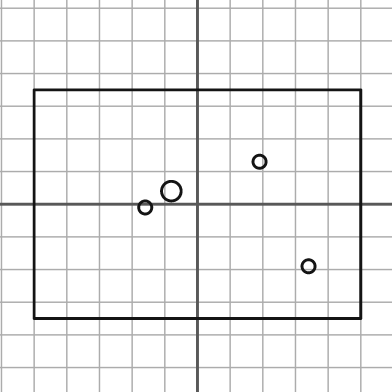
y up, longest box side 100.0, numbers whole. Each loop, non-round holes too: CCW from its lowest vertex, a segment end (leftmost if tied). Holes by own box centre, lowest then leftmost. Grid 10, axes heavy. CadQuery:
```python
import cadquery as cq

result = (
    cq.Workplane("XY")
    .moveTo(-50.0, -35.0)
    .lineTo(50.0, -35.0)
    .lineTo(50.0, 35.0)
    .lineTo(-50.0, 35.0)
    .close()
    .moveTo(34.0, -19.0)
    .circle(2.0)
    .moveTo(-16.0, -1.0)
    .circle(2.0)
    .moveTo(-8.0, 4.0)
    .circle(3.0)
    .moveTo(19.0, 13.0)
    .circle(2.0)
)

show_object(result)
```